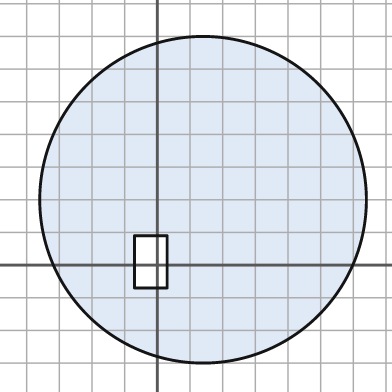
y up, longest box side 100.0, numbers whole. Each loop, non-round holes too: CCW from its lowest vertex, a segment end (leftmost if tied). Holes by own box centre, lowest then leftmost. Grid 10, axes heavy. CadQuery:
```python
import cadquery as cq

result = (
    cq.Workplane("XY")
    .moveTo(14.0, 20.0)
    .circle(50.0)
    .moveTo(-7.0, -7.0)
    .lineTo(3.0, -7.0)
    .lineTo(3.0, 9.0)
    .lineTo(-7.0, 9.0)
    .close()
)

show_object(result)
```